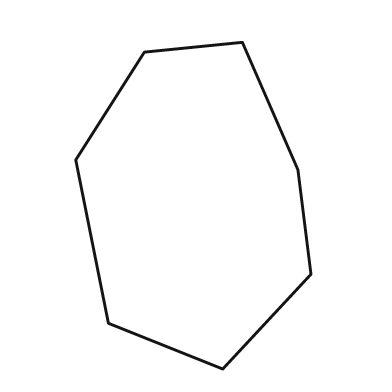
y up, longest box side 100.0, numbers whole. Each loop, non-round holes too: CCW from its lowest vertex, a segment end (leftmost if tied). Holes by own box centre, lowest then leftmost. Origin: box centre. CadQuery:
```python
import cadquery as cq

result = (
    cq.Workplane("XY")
    .moveTo(9.0, -50.0)
    .lineTo(36.0, -21.0)
    .lineTo(32.0, 11.0)
    .lineTo(15.0, 50.0)
    .lineTo(-15.0, 47.0)
    .lineTo(-36.0, 14.0)
    .lineTo(-26.0, -36.0)
    .close()
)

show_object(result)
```